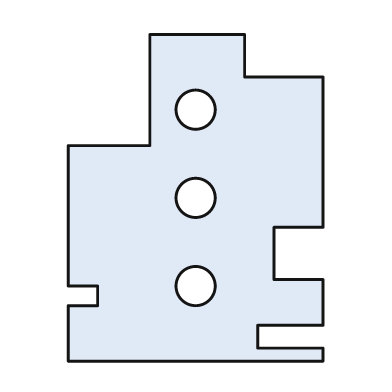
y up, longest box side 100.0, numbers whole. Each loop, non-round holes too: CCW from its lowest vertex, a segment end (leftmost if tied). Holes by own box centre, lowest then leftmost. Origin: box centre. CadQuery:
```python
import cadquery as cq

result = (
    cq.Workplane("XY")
    .moveTo(-39.0, -50.0)
    .lineTo(39.0, -50.0)
    .lineTo(39.0, -46.0)
    .lineTo(19.0, -46.0)
    .lineTo(19.0, -39.0)
    .lineTo(39.0, -39.0)
    .lineTo(39.0, -25.0)
    .lineTo(24.0, -25.0)
    .lineTo(24.0, -9.0)
    .lineTo(39.0, -9.0)
    .lineTo(39.0, 37.0)
    .lineTo(15.0, 37.0)
    .lineTo(15.0, 50.0)
    .lineTo(-14.0, 50.0)
    .lineTo(-14.0, 16.0)
    .lineTo(-39.0, 16.0)
    .lineTo(-39.0, -27.0)
    .lineTo(-30.0, -27.0)
    .lineTo(-30.0, -33.0)
    .lineTo(-39.0, -33.0)
    .close()
    .moveTo(0.0, -27.0)
    .circle(6.0)
    .moveTo(0.0, 0.0)
    .circle(6.0)
    .moveTo(0.0, 27.0)
    .circle(6.0)
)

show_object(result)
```